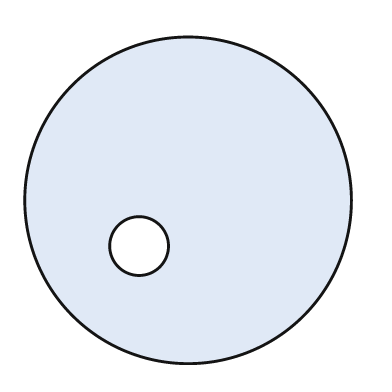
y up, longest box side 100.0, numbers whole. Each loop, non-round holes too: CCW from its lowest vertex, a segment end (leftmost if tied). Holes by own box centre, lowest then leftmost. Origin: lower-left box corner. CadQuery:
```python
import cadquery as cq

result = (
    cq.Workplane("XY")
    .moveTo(50.0, 50.0)
    .circle(50.0)
    .moveTo(35.0, 36.0)
    .circle(9.0)
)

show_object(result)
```